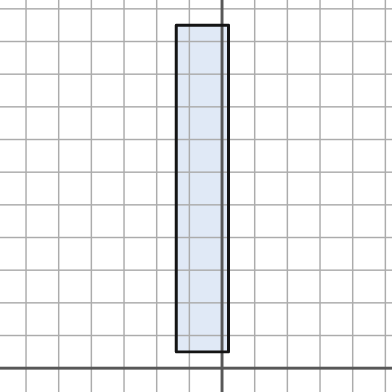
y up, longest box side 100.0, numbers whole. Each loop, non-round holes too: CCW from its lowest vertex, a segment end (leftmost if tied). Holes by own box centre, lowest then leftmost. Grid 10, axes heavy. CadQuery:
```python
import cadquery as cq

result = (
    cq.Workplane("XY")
    .moveTo(-14.0, 5.0)
    .lineTo(2.0, 5.0)
    .lineTo(2.0, 105.0)
    .lineTo(-14.0, 105.0)
    .close()
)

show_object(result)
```